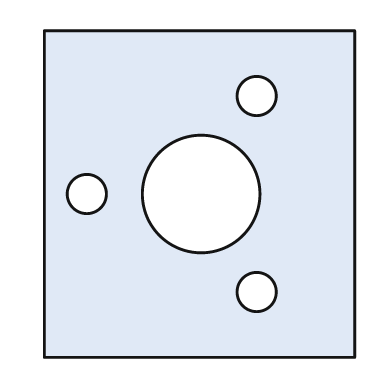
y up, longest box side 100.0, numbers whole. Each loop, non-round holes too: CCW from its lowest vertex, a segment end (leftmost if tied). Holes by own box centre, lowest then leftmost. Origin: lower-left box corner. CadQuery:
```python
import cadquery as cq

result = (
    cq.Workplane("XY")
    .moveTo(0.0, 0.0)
    .lineTo(95.0, 0.0)
    .lineTo(95.0, 100.0)
    .lineTo(0.0, 100.0)
    .close()
    .moveTo(65.0, 20.0)
    .circle(6.0)
    .moveTo(13.0, 50.0)
    .circle(6.0)
    .moveTo(48.0, 50.0)
    .circle(18.0)
    .moveTo(65.0, 80.0)
    .circle(6.0)
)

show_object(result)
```